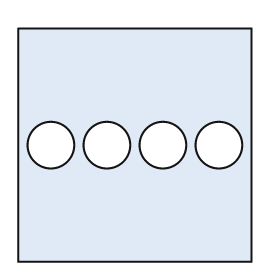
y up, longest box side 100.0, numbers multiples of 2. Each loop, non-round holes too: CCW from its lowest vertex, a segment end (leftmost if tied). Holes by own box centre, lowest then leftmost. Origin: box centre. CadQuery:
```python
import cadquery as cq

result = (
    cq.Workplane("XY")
    .moveTo(-50.0, -50.0)
    .lineTo(50.0, -50.0)
    .lineTo(50.0, 50.0)
    .lineTo(-50.0, 50.0)
    .close()
    .moveTo(-36.0, 0.0)
    .circle(10.0)
    .moveTo(-12.0, 0.0)
    .circle(10.0)
    .moveTo(12.0, 0.0)
    .circle(10.0)
    .moveTo(36.0, 0.0)
    .circle(10.0)
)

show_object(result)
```